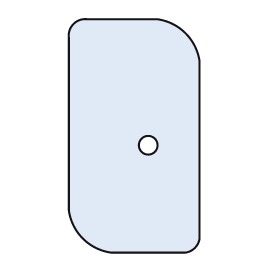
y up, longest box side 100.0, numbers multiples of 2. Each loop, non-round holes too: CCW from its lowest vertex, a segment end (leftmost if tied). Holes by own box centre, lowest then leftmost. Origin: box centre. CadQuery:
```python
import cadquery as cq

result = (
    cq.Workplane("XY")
    .moveTo(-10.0, -50.0)
    .lineTo(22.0, -50.0)
    .threePointArc((26.0, -48.0), (28.0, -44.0))
    .lineTo(28.0, 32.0)
    .threePointArc((22.0, 44.0), (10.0, 50.0))
    .lineTo(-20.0, 50.0)
    .threePointArc((-26.0, 48.0), (-28.0, 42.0))
    .lineTo(-28.0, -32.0)
    .threePointArc((-22.0, -44.0), (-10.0, -50.0))
    .close()
    .moveTo(6.0, -4.0)
    .circle(4.0)
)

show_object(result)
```